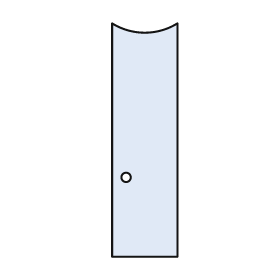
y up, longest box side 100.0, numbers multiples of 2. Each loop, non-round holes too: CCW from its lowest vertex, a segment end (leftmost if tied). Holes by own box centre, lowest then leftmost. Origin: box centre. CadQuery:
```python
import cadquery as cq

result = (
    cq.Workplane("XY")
    .moveTo(-14.0, -50.0)
    .lineTo(14.0, -50.0)
    .lineTo(14.0, 50.0)
    .threePointArc((0.0, 46.0), (-14.0, 50.0))
    .close()
    .moveTo(-8.0, -16.0)
    .circle(2.0)
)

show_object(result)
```